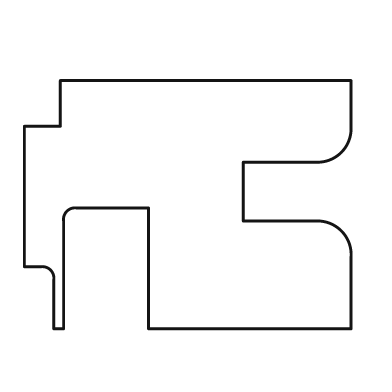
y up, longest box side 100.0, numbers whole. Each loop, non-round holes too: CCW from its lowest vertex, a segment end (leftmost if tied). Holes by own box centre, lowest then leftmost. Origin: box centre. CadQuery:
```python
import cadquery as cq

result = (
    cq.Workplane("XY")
    .moveTo(-41.0, -38.0)
    .lineTo(-38.0, -38.0)
    .lineTo(-38.0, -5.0)
    .threePointArc((-37.0, -2.0), (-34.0, -1.0))
    .lineTo(-12.0, -1.0)
    .lineTo(-12.0, -38.0)
    .lineTo(50.0, -38.0)
    .lineTo(50.0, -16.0)
    .threePointArc((47.0, -8.0), (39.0, -5.0))
    .lineTo(17.0, -5.0)
    .lineTo(17.0, 13.0)
    .lineTo(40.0, 13.0)
    .threePointArc((47.0, 16.0), (50.0, 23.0))
    .lineTo(50.0, 38.0)
    .lineTo(-39.0, 38.0)
    .lineTo(-39.0, 24.0)
    .lineTo(-50.0, 24.0)
    .lineTo(-50.0, -19.0)
    .lineTo(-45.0, -19.0)
    .threePointArc((-42.0, -20.0), (-41.0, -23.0))
    .close()
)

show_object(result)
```